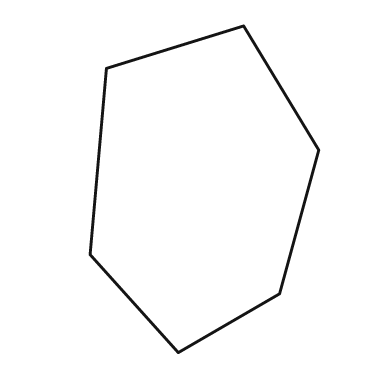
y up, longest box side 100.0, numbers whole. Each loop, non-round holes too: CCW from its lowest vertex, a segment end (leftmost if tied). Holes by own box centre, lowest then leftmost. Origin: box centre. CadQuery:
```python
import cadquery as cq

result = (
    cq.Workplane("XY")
    .moveTo(-8.0, -50.0)
    .lineTo(23.0, -32.0)
    .lineTo(35.0, 12.0)
    .lineTo(12.0, 50.0)
    .lineTo(-30.0, 37.0)
    .lineTo(-35.0, -20.0)
    .close()
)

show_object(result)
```